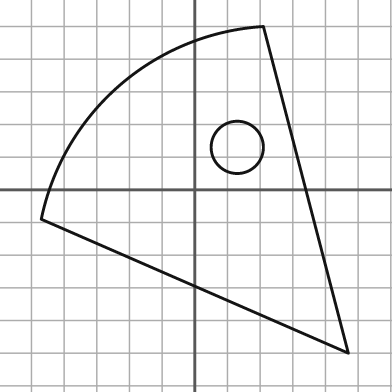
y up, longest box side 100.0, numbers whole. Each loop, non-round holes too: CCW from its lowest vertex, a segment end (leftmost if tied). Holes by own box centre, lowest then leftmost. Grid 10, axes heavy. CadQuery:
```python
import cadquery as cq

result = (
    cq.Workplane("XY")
    .moveTo(47.0, -50.0)
    .lineTo(21.0, 50.0)
    .threePointArc((-23.0, 32.0), (-47.0, -9.0))
    .close()
    .moveTo(13.0, 13.0)
    .circle(8.0)
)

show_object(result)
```